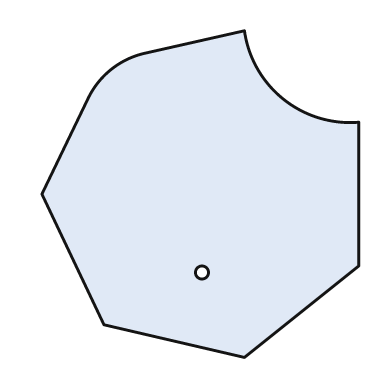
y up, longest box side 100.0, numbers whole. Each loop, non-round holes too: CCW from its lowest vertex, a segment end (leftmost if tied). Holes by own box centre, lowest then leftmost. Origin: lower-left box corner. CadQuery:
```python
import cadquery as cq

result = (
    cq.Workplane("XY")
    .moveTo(62.0, 0.0)
    .lineTo(97.0, 28.0)
    .lineTo(97.0, 72.0)
    .threePointArc((74.0, 79.0), (62.0, 100.0))
    .lineTo(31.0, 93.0)
    .threePointArc((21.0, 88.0), (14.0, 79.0))
    .lineTo(0.0, 50.0)
    .lineTo(19.0, 10.0)
    .close()
    .moveTo(49.0, 26.0)
    .circle(2.0)
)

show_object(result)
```